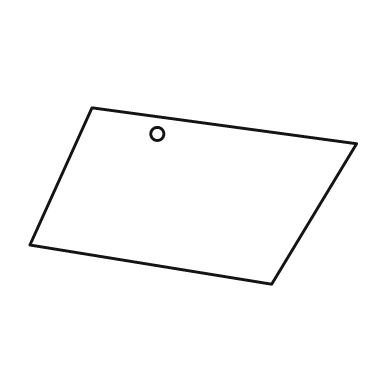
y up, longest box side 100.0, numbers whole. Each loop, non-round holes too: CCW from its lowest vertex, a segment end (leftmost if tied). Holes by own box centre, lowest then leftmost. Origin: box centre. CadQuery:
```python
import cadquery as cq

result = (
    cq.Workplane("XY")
    .moveTo(24.0, -27.0)
    .lineTo(50.0, 16.0)
    .lineTo(-31.0, 27.0)
    .lineTo(-50.0, -15.0)
    .close()
    .moveTo(-11.0, 19.0)
    .circle(2.0)
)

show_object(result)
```